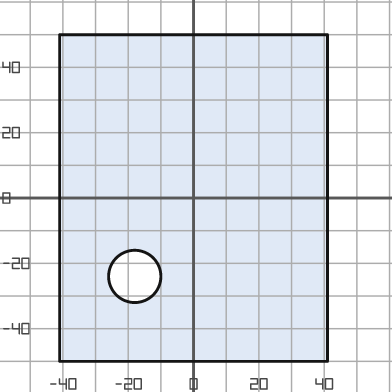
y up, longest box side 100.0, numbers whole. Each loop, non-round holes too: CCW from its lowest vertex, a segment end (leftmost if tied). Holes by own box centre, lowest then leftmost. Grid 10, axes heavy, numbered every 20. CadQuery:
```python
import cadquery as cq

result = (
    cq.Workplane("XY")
    .moveTo(-41.0, -50.0)
    .lineTo(41.0, -50.0)
    .lineTo(41.0, 50.0)
    .lineTo(-41.0, 50.0)
    .close()
    .moveTo(-18.0, -24.0)
    .circle(8.0)
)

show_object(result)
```